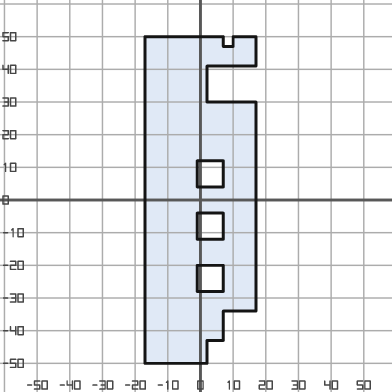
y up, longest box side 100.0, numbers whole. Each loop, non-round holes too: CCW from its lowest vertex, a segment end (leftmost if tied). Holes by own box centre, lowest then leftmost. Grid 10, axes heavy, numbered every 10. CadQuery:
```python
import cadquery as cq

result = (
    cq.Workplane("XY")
    .moveTo(-17.0, -50.0)
    .lineTo(2.0, -50.0)
    .lineTo(2.0, -43.0)
    .lineTo(7.0, -43.0)
    .lineTo(7.0, -34.0)
    .lineTo(17.0, -34.0)
    .lineTo(17.0, 30.0)
    .lineTo(2.0, 30.0)
    .lineTo(2.0, 41.0)
    .lineTo(17.0, 41.0)
    .lineTo(17.0, 50.0)
    .lineTo(10.0, 50.0)
    .lineTo(10.0, 47.0)
    .lineTo(7.0, 47.0)
    .lineTo(7.0, 50.0)
    .lineTo(-17.0, 50.0)
    .close()
    .moveTo(-1.0, -28.0)
    .lineTo(7.0, -28.0)
    .lineTo(7.0, -20.0)
    .lineTo(-1.0, -20.0)
    .close()
    .moveTo(-1.0, -12.0)
    .lineTo(7.0, -12.0)
    .lineTo(7.0, -4.0)
    .lineTo(-1.0, -4.0)
    .close()
    .moveTo(-1.0, 4.0)
    .lineTo(7.0, 4.0)
    .lineTo(7.0, 12.0)
    .lineTo(-1.0, 12.0)
    .close()
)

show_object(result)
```